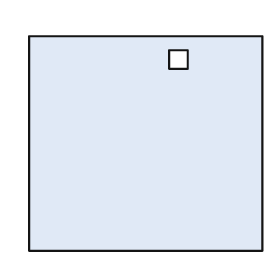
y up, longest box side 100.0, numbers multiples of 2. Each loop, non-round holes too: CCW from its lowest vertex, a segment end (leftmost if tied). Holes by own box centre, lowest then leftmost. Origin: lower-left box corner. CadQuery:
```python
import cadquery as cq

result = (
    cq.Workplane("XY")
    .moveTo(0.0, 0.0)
    .lineTo(100.0, 0.0)
    .lineTo(100.0, 92.0)
    .lineTo(0.0, 92.0)
    .close()
    .moveTo(60.0, 78.0)
    .lineTo(68.0, 78.0)
    .lineTo(68.0, 86.0)
    .lineTo(60.0, 86.0)
    .close()
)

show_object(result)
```